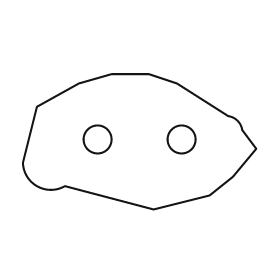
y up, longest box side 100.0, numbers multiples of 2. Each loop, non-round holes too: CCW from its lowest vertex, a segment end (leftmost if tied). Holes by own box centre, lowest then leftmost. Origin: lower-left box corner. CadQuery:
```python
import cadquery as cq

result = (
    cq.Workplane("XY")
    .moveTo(56.0, 0.0)
    .lineTo(80.0, 6.0)
    .lineTo(90.0, 14.0)
    .lineTo(100.0, 26.0)
    .lineTo(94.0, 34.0)
    .threePointArc((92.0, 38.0), (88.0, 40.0))
    .lineTo(66.0, 54.0)
    .lineTo(54.0, 58.0)
    .lineTo(38.0, 58.0)
    .lineTo(24.0, 54.0)
    .lineTo(6.0, 44.0)
    .lineTo(0.0, 20.0)
    .threePointArc((6.0, 10.0), (18.0, 10.0))
    .close()
    .moveTo(32.0, 30.0)
    .circle(6.0)
    .moveTo(68.0, 30.0)
    .circle(6.0)
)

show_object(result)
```